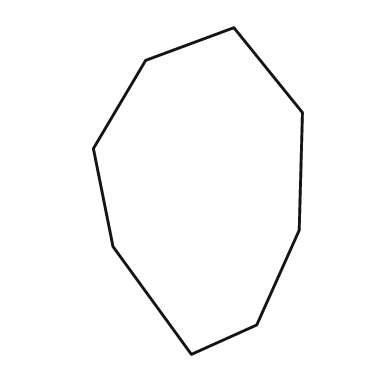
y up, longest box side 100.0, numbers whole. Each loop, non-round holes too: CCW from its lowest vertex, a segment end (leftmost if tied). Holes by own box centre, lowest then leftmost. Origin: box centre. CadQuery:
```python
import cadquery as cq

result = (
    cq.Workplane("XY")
    .moveTo(-2.0, -50.0)
    .lineTo(18.0, -41.0)
    .lineTo(31.0, -12.0)
    .lineTo(32.0, 24.0)
    .lineTo(11.0, 50.0)
    .lineTo(-16.0, 40.0)
    .lineTo(-32.0, 13.0)
    .lineTo(-26.0, -17.0)
    .close()
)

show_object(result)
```